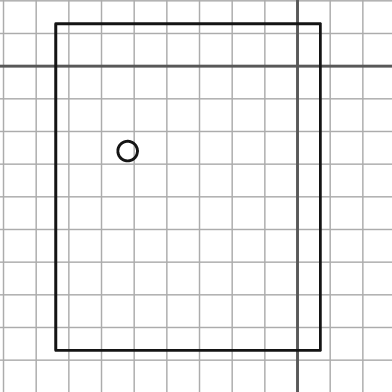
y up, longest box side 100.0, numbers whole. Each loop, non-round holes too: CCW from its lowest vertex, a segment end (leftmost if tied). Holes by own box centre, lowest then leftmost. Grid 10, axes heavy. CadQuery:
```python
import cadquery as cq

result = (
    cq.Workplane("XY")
    .moveTo(-74.0, -87.0)
    .lineTo(7.0, -87.0)
    .lineTo(7.0, 13.0)
    .lineTo(-74.0, 13.0)
    .close()
    .moveTo(-52.0, -26.0)
    .circle(3.0)
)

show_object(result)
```